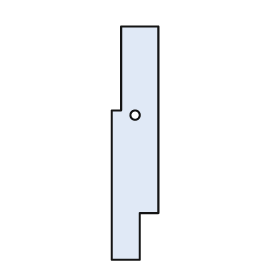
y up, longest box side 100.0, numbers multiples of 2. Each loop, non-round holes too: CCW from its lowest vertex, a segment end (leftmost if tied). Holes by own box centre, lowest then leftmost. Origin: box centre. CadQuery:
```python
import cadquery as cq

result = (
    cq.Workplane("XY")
    .moveTo(-10.0, -50.0)
    .lineTo(2.0, -50.0)
    .lineTo(2.0, -30.0)
    .lineTo(10.0, -30.0)
    .lineTo(10.0, 50.0)
    .lineTo(-6.0, 50.0)
    .lineTo(-6.0, 14.0)
    .lineTo(-10.0, 14.0)
    .close()
    .moveTo(0.0, 12.0)
    .circle(2.0)
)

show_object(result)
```